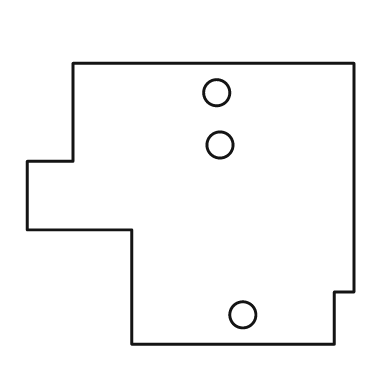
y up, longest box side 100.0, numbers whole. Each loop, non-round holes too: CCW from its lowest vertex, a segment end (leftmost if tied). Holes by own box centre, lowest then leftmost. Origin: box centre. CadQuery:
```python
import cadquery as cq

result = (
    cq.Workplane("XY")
    .moveTo(-18.0, -43.0)
    .lineTo(44.0, -43.0)
    .lineTo(44.0, -27.0)
    .lineTo(50.0, -27.0)
    .lineTo(50.0, 43.0)
    .lineTo(-36.0, 43.0)
    .lineTo(-36.0, 13.0)
    .lineTo(-50.0, 13.0)
    .lineTo(-50.0, -8.0)
    .lineTo(-18.0, -8.0)
    .close()
    .moveTo(16.0, -34.0)
    .circle(4.0)
    .moveTo(9.0, 18.0)
    .circle(4.0)
    .moveTo(8.0, 34.0)
    .circle(4.0)
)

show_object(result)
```